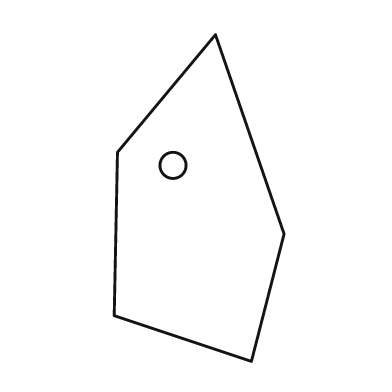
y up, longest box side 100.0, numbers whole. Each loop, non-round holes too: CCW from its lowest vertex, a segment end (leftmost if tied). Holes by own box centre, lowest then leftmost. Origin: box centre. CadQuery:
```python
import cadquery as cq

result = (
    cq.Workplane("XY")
    .moveTo(16.0, -50.0)
    .lineTo(26.0, -11.0)
    .lineTo(5.0, 50.0)
    .lineTo(-25.0, 14.0)
    .lineTo(-26.0, -36.0)
    .close()
    .moveTo(-8.0, 10.0)
    .circle(4.0)
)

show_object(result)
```